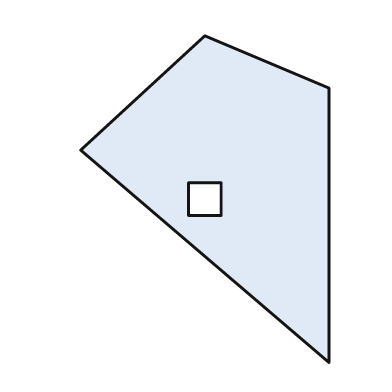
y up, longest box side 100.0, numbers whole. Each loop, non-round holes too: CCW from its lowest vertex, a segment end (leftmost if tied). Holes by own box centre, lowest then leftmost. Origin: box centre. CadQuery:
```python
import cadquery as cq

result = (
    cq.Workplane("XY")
    .moveTo(38.0, -50.0)
    .lineTo(38.0, 34.0)
    .lineTo(0.0, 50.0)
    .lineTo(-38.0, 15.0)
    .close()
    .moveTo(-5.0, -5.0)
    .lineTo(5.0, -5.0)
    .lineTo(5.0, 5.0)
    .lineTo(-5.0, 5.0)
    .close()
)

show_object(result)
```